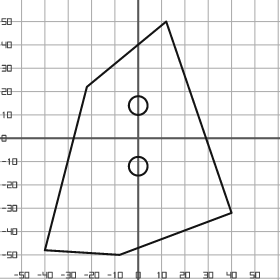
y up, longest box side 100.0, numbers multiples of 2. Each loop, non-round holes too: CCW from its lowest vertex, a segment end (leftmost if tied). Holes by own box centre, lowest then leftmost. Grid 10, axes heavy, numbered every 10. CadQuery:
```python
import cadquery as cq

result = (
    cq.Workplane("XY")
    .moveTo(-8.0, -50.0)
    .lineTo(40.0, -32.0)
    .lineTo(12.0, 50.0)
    .lineTo(-22.0, 22.0)
    .lineTo(-40.0, -48.0)
    .close()
    .moveTo(0.0, -12.0)
    .circle(4.0)
    .moveTo(0.0, 14.0)
    .circle(4.0)
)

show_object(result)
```